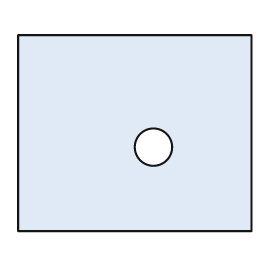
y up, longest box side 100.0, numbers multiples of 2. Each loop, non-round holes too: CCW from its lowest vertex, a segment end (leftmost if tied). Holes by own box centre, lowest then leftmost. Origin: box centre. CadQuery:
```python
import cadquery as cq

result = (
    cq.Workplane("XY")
    .moveTo(-50.0, -42.0)
    .lineTo(50.0, -42.0)
    .lineTo(50.0, 42.0)
    .lineTo(-50.0, 42.0)
    .close()
    .moveTo(8.0, -6.0)
    .circle(8.0)
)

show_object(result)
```